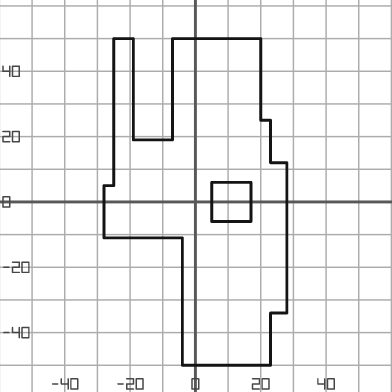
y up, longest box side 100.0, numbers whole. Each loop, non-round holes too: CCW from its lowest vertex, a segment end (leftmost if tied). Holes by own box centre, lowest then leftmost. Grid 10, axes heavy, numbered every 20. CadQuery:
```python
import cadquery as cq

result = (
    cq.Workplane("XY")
    .moveTo(-4.0, -50.0)
    .lineTo(23.0, -50.0)
    .lineTo(23.0, -34.0)
    .lineTo(28.0, -34.0)
    .lineTo(28.0, 12.0)
    .lineTo(23.0, 12.0)
    .lineTo(23.0, 25.0)
    .lineTo(20.0, 25.0)
    .lineTo(20.0, 50.0)
    .lineTo(-7.0, 50.0)
    .lineTo(-7.0, 19.0)
    .lineTo(-19.0, 19.0)
    .lineTo(-19.0, 50.0)
    .lineTo(-25.0, 50.0)
    .lineTo(-25.0, 5.0)
    .lineTo(-28.0, 5.0)
    .lineTo(-28.0, -11.0)
    .lineTo(-4.0, -11.0)
    .close()
    .moveTo(5.0, -6.0)
    .lineTo(17.0, -6.0)
    .lineTo(17.0, 6.0)
    .lineTo(5.0, 6.0)
    .close()
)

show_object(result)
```